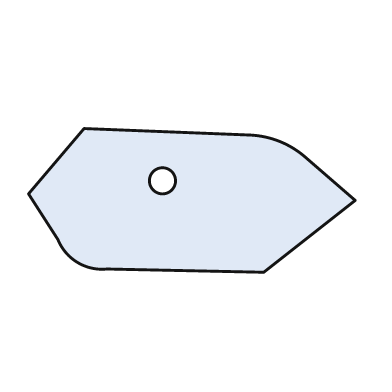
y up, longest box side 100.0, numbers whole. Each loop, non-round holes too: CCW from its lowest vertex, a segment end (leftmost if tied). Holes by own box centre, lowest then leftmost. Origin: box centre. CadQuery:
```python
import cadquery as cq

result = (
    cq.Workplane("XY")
    .moveTo(22.0, -22.0)
    .lineTo(50.0, 0.0)
    .lineTo(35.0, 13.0)
    .threePointArc((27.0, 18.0), (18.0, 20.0))
    .lineTo(-33.0, 22.0)
    .lineTo(-50.0, 2.0)
    .lineTo(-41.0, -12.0)
    .threePointArc((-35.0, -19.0), (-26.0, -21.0))
    .close()
    .moveTo(-9.0, 6.0)
    .circle(4.0)
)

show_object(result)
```